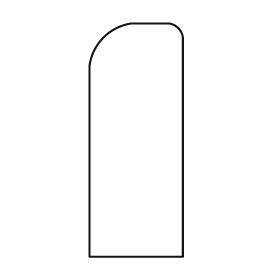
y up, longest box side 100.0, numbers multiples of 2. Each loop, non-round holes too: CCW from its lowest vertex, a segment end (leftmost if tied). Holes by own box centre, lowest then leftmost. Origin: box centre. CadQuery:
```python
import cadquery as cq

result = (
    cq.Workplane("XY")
    .moveTo(-20.0, -50.0)
    .lineTo(20.0, -50.0)
    .lineTo(20.0, 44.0)
    .threePointArc((18.0, 48.0), (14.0, 50.0))
    .lineTo(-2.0, 50.0)
    .threePointArc((-14.0, 44.0), (-20.0, 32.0))
    .close()
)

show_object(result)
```